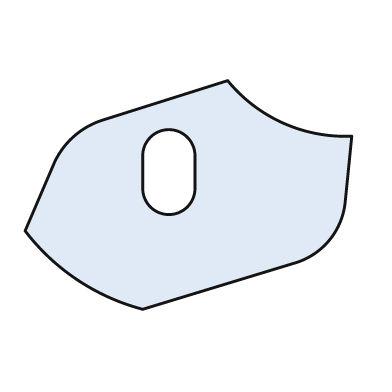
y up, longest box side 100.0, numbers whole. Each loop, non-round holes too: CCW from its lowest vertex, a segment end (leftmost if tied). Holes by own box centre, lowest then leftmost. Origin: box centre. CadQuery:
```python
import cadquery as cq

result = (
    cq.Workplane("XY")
    .moveTo(-14.0, -35.0)
    .lineTo(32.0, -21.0)
    .threePointArc((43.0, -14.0), (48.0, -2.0))
    .lineTo(50.0, 18.0)
    .threePointArc((29.0, 22.0), (12.0, 35.0))
    .lineTo(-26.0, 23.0)
    .threePointArc((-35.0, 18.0), (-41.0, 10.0))
    .lineTo(-50.0, -11.0)
    .threePointArc((-34.0, -26.0), (-14.0, -35.0))
    .close()
    .moveTo(-14.0, 2.0)
    .threePointArc((-6.0, -6.0), (2.0, 2.0))
    .lineTo(2.0, 12.0)
    .threePointArc((-6.0, 20.0), (-14.0, 12.0))
    .close()
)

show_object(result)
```